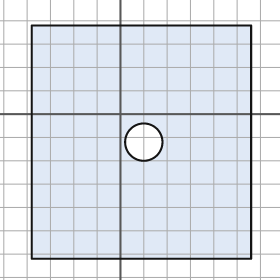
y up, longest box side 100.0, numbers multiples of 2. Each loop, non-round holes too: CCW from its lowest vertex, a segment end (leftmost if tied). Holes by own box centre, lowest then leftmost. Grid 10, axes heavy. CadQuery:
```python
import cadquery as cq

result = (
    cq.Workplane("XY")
    .moveTo(-38.0, -62.0)
    .lineTo(56.0, -62.0)
    .lineTo(56.0, 38.0)
    .lineTo(-38.0, 38.0)
    .close()
    .moveTo(10.0, -12.0)
    .circle(8.0)
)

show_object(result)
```